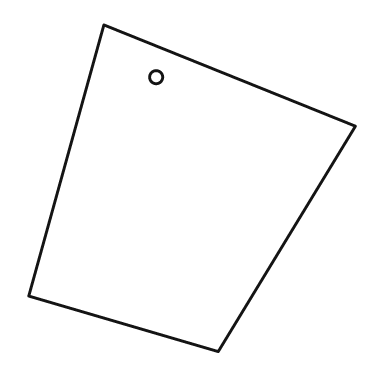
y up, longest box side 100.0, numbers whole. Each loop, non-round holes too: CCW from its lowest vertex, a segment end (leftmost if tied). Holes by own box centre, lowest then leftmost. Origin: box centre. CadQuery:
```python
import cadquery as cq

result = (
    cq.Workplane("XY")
    .moveTo(8.0, -50.0)
    .lineTo(50.0, 19.0)
    .lineTo(-27.0, 50.0)
    .lineTo(-50.0, -33.0)
    .close()
    .moveTo(-11.0, 34.0)
    .circle(2.0)
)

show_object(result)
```